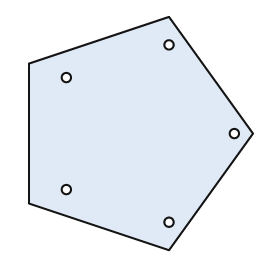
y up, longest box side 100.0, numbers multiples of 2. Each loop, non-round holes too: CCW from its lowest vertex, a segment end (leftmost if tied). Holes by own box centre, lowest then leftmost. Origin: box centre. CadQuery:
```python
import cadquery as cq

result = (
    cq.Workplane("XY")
    .moveTo(12.0, -50.0)
    .lineTo(48.0, 0.0)
    .lineTo(12.0, 50.0)
    .lineTo(-48.0, 30.0)
    .lineTo(-48.0, -30.0)
    .close()
    .moveTo(12.0, -38.0)
    .circle(2.0)
    .moveTo(-32.0, -24.0)
    .circle(2.0)
    .moveTo(40.0, 0.0)
    .circle(2.0)
    .moveTo(-32.0, 24.0)
    .circle(2.0)
    .moveTo(12.0, 38.0)
    .circle(2.0)
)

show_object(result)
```